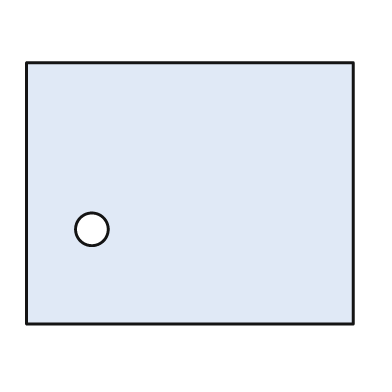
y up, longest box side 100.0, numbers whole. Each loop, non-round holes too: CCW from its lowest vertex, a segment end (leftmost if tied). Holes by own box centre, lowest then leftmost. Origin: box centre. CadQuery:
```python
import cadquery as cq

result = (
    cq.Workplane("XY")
    .moveTo(-50.0, -40.0)
    .lineTo(50.0, -40.0)
    .lineTo(50.0, 40.0)
    .lineTo(-50.0, 40.0)
    .close()
    .moveTo(-30.0, -11.0)
    .circle(5.0)
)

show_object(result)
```